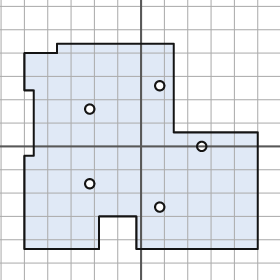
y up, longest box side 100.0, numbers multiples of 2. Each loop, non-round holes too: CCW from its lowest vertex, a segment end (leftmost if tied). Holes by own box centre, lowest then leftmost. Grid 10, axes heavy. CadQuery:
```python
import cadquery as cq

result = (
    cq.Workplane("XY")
    .moveTo(-50.0, -44.0)
    .lineTo(-18.0, -44.0)
    .lineTo(-18.0, -30.0)
    .lineTo(-2.0, -30.0)
    .lineTo(-2.0, -44.0)
    .lineTo(50.0, -44.0)
    .lineTo(50.0, 6.0)
    .lineTo(14.0, 6.0)
    .lineTo(14.0, 44.0)
    .lineTo(-36.0, 44.0)
    .lineTo(-36.0, 40.0)
    .lineTo(-50.0, 40.0)
    .lineTo(-50.0, 24.0)
    .lineTo(-46.0, 24.0)
    .lineTo(-46.0, -4.0)
    .lineTo(-50.0, -4.0)
    .close()
    .moveTo(8.0, -26.0)
    .circle(2.0)
    .moveTo(-22.0, -16.0)
    .circle(2.0)
    .moveTo(26.0, 0.0)
    .circle(2.0)
    .moveTo(-22.0, 16.0)
    .circle(2.0)
    .moveTo(8.0, 26.0)
    .circle(2.0)
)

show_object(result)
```